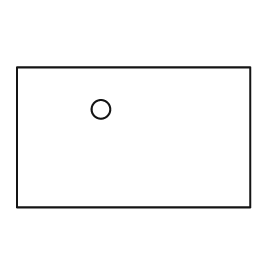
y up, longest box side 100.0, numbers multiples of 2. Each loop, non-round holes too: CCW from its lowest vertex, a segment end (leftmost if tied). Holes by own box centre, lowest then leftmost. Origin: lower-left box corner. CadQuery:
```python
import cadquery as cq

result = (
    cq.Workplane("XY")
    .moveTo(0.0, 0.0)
    .lineTo(100.0, 0.0)
    .lineTo(100.0, 60.0)
    .lineTo(0.0, 60.0)
    .close()
    .moveTo(36.0, 42.0)
    .circle(4.0)
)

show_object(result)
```